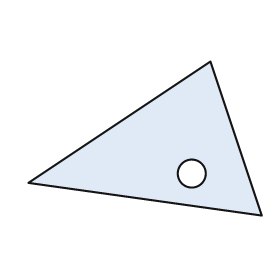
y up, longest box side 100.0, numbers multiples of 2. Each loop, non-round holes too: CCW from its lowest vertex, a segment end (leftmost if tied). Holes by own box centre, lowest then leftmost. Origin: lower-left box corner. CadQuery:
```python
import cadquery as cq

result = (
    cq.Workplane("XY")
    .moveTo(100.0, 0.0)
    .lineTo(78.0, 66.0)
    .lineTo(0.0, 14.0)
    .close()
    .moveTo(70.0, 18.0)
    .circle(6.0)
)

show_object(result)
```